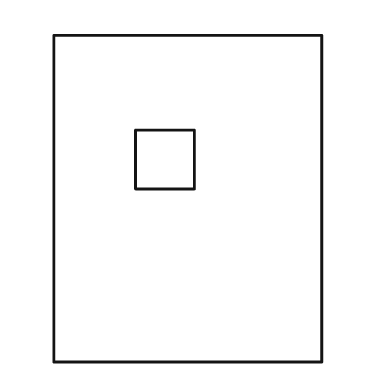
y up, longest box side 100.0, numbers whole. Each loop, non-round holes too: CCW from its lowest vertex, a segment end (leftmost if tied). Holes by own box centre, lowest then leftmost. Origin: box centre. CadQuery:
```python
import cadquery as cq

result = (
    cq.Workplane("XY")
    .moveTo(-41.0, -50.0)
    .lineTo(41.0, -50.0)
    .lineTo(41.0, 50.0)
    .lineTo(-41.0, 50.0)
    .close()
    .moveTo(-16.0, 3.0)
    .lineTo(2.0, 3.0)
    .lineTo(2.0, 21.0)
    .lineTo(-16.0, 21.0)
    .close()
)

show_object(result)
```